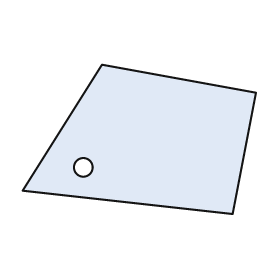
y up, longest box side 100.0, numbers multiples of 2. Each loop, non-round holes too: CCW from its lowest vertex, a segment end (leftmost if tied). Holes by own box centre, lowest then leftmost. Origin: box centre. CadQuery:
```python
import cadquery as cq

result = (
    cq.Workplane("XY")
    .moveTo(40.0, -32.0)
    .lineTo(50.0, 20.0)
    .lineTo(-16.0, 32.0)
    .lineTo(-50.0, -22.0)
    .close()
    .moveTo(-24.0, -12.0)
    .circle(4.0)
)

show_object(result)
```